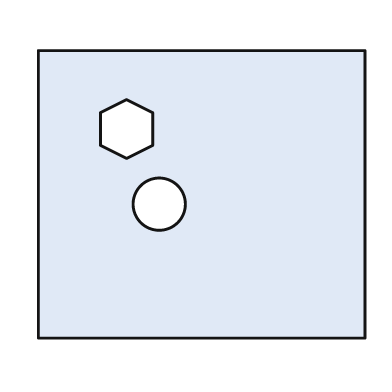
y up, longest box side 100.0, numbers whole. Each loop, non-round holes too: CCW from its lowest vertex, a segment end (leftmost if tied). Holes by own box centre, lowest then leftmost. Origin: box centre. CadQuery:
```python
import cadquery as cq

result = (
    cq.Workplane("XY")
    .moveTo(-50.0, -44.0)
    .lineTo(50.0, -44.0)
    .lineTo(50.0, 44.0)
    .lineTo(-50.0, 44.0)
    .close()
    .moveTo(-13.0, -3.0)
    .circle(8.0)
    .moveTo(-23.0, 11.0)
    .lineTo(-15.0, 15.0)
    .lineTo(-15.0, 25.0)
    .lineTo(-23.0, 29.0)
    .lineTo(-31.0, 25.0)
    .lineTo(-31.0, 15.0)
    .close()
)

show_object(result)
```